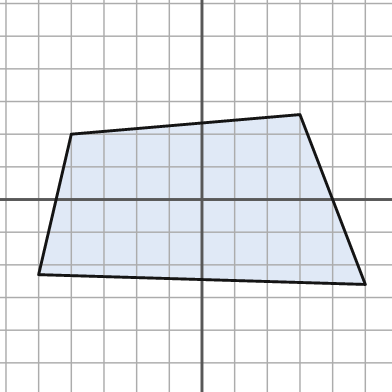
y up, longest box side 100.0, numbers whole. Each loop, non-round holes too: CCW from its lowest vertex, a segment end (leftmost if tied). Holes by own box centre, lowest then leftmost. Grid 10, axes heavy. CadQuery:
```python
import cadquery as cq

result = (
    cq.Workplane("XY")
    .moveTo(50.0, -26.0)
    .lineTo(30.0, 26.0)
    .lineTo(-40.0, 20.0)
    .lineTo(-50.0, -23.0)
    .close()
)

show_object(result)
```